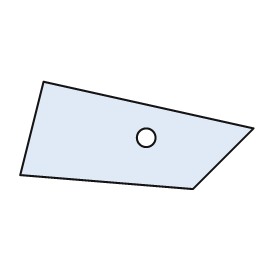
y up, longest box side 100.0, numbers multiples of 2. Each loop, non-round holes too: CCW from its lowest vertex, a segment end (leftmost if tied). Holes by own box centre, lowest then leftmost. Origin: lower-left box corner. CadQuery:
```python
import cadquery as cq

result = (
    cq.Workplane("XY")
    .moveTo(74.0, 0.0)
    .lineTo(100.0, 26.0)
    .lineTo(10.0, 46.0)
    .lineTo(0.0, 6.0)
    .close()
    .moveTo(54.0, 22.0)
    .circle(4.0)
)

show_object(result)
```